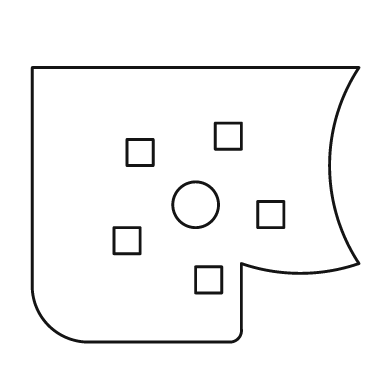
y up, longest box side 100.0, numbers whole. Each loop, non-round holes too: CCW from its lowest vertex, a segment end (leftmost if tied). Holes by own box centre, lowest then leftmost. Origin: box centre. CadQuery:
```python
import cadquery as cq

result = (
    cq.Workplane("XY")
    .moveTo(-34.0, -42.0)
    .lineTo(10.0, -42.0)
    .threePointArc((13.0, -41.0), (14.0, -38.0))
    .lineTo(14.0, -18.0)
    .threePointArc((32.0, -21.0), (50.0, -18.0))
    .threePointArc((41.0, 12.0), (50.0, 42.0))
    .lineTo(-50.0, 42.0)
    .lineTo(-50.0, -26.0)
    .threePointArc((-45.0, -37.0), (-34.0, -42.0))
    .close()
    .moveTo(0.0, -27.0)
    .lineTo(8.0, -27.0)
    .lineTo(8.0, -19.0)
    .lineTo(0.0, -19.0)
    .close()
    .moveTo(-25.0, -15.0)
    .lineTo(-17.0, -15.0)
    .lineTo(-17.0, -7.0)
    .lineTo(-25.0, -7.0)
    .close()
    .moveTo(19.0, -7.0)
    .lineTo(27.0, -7.0)
    .lineTo(27.0, 1.0)
    .lineTo(19.0, 1.0)
    .close()
    .moveTo(0.0, 0.0)
    .circle(7.0)
    .moveTo(-21.0, 12.0)
    .lineTo(-13.0, 12.0)
    .lineTo(-13.0, 20.0)
    .lineTo(-21.0, 20.0)
    .close()
    .moveTo(6.0, 17.0)
    .lineTo(14.0, 17.0)
    .lineTo(14.0, 25.0)
    .lineTo(6.0, 25.0)
    .close()
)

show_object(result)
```